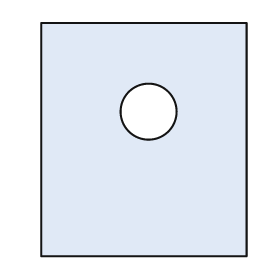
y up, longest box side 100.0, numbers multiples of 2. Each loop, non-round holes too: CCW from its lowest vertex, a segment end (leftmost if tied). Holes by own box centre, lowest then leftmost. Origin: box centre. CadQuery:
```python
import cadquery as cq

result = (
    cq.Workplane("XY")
    .moveTo(-44.0, -50.0)
    .lineTo(44.0, -50.0)
    .lineTo(44.0, 50.0)
    .lineTo(-44.0, 50.0)
    .close()
    .moveTo(2.0, 12.0)
    .circle(12.0)
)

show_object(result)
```